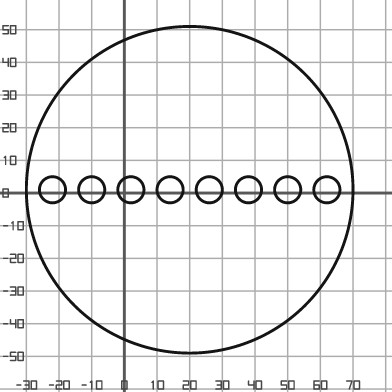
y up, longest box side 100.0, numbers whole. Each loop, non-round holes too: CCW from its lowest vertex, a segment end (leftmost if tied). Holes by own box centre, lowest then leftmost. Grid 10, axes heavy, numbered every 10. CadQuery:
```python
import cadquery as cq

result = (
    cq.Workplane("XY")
    .moveTo(20.0, 1.0)
    .circle(50.0)
    .moveTo(-22.0, 1.0)
    .circle(4.0)
    .moveTo(-10.0, 1.0)
    .circle(4.0)
    .moveTo(2.0, 1.0)
    .circle(4.0)
    .moveTo(14.0, 1.0)
    .circle(4.0)
    .moveTo(26.0, 1.0)
    .circle(4.0)
    .moveTo(38.0, 1.0)
    .circle(4.0)
    .moveTo(50.0, 1.0)
    .circle(4.0)
    .moveTo(62.0, 1.0)
    .circle(4.0)
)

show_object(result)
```